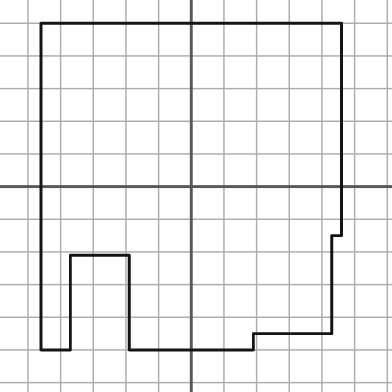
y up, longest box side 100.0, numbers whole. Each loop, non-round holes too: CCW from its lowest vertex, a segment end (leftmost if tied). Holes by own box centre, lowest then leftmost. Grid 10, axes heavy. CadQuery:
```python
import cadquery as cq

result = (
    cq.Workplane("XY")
    .moveTo(-46.0, -50.0)
    .lineTo(-37.0, -50.0)
    .lineTo(-37.0, -21.0)
    .lineTo(-19.0, -21.0)
    .lineTo(-19.0, -50.0)
    .lineTo(19.0, -50.0)
    .lineTo(19.0, -45.0)
    .lineTo(43.0, -45.0)
    .lineTo(43.0, -15.0)
    .lineTo(46.0, -15.0)
    .lineTo(46.0, 50.0)
    .lineTo(-46.0, 50.0)
    .close()
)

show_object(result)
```